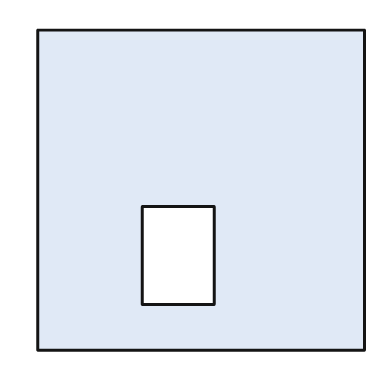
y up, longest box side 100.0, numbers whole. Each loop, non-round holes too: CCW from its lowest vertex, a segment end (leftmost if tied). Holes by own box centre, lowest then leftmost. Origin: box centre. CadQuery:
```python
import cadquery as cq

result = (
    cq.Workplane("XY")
    .moveTo(-50.0, -49.0)
    .lineTo(50.0, -49.0)
    .lineTo(50.0, 49.0)
    .lineTo(-50.0, 49.0)
    .close()
    .moveTo(-18.0, -35.0)
    .lineTo(4.0, -35.0)
    .lineTo(4.0, -5.0)
    .lineTo(-18.0, -5.0)
    .close()
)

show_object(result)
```